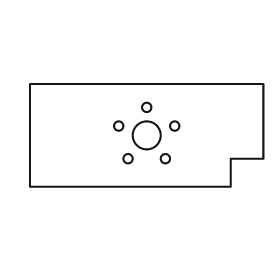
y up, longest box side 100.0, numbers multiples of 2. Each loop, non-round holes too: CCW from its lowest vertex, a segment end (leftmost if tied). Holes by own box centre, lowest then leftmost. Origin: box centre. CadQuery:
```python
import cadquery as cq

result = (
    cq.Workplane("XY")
    .moveTo(-50.0, -22.0)
    .lineTo(36.0, -22.0)
    .lineTo(36.0, -10.0)
    .lineTo(50.0, -10.0)
    .lineTo(50.0, 22.0)
    .lineTo(-50.0, 22.0)
    .close()
    .moveTo(-8.0, -10.0)
    .circle(2.0)
    .moveTo(8.0, -10.0)
    .circle(2.0)
    .moveTo(0.0, 0.0)
    .circle(6.0)
    .moveTo(-12.0, 4.0)
    .circle(2.0)
    .moveTo(12.0, 4.0)
    .circle(2.0)
    .moveTo(0.0, 12.0)
    .circle(2.0)
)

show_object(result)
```